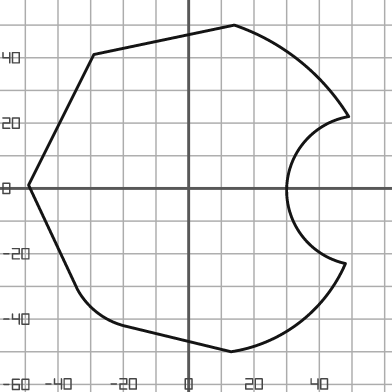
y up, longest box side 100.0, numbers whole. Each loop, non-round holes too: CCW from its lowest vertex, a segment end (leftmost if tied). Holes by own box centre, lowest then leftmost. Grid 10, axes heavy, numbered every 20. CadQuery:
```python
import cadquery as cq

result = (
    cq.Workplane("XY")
    .moveTo(13.0, -50.0)
    .threePointArc((34.0, -41.0), (48.0, -23.0))
    .threePointArc((30.0, 0.0), (49.0, 22.0))
    .threePointArc((34.0, 39.0), (14.0, 50.0))
    .lineTo(-29.0, 41.0)
    .lineTo(-49.0, 1.0)
    .lineTo(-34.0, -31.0)
    .threePointArc((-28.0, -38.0), (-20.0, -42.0))
    .close()
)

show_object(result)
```